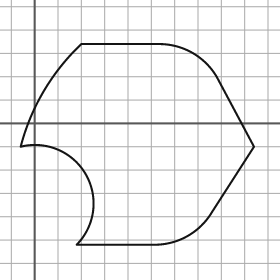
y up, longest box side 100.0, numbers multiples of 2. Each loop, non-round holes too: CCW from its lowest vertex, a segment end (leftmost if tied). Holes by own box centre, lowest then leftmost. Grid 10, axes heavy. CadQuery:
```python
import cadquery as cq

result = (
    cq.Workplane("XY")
    .moveTo(18.0, -52.0)
    .lineTo(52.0, -52.0)
    .threePointArc((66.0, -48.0), (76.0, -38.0))
    .lineTo(94.0, -10.0)
    .lineTo(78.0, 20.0)
    .threePointArc((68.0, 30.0), (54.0, 34.0))
    .lineTo(20.0, 34.0)
    .threePointArc((4.0, 14.0), (-6.0, -10.0))
    .threePointArc((22.0, -22.0), (18.0, -52.0))
    .close()
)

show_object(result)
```